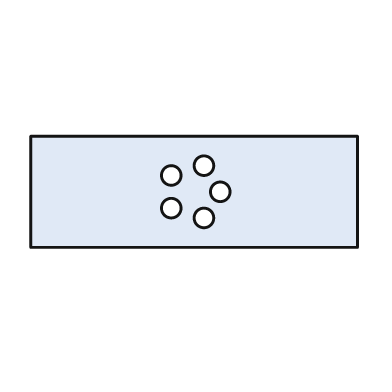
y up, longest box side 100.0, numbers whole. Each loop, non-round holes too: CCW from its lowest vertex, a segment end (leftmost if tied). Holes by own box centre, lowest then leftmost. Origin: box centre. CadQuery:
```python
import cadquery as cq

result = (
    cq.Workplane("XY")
    .moveTo(-50.0, -17.0)
    .lineTo(50.0, -17.0)
    .lineTo(50.0, 17.0)
    .lineTo(-50.0, 17.0)
    .close()
    .moveTo(3.0, -8.0)
    .circle(3.0)
    .moveTo(-7.0, -5.0)
    .circle(3.0)
    .moveTo(8.0, 0.0)
    .circle(3.0)
    .moveTo(-7.0, 5.0)
    .circle(3.0)
    .moveTo(3.0, 8.0)
    .circle(3.0)
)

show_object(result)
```